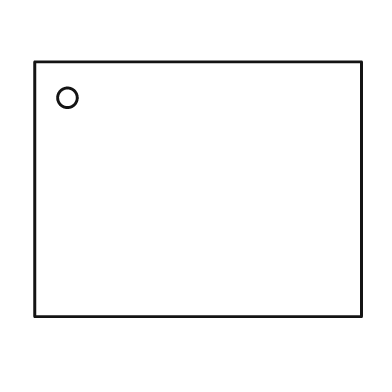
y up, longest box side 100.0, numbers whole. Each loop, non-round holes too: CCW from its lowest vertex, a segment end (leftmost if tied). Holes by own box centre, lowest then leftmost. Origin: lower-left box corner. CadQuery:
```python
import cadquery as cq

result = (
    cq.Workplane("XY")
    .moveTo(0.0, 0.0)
    .lineTo(100.0, 0.0)
    .lineTo(100.0, 78.0)
    .lineTo(0.0, 78.0)
    .close()
    .moveTo(10.0, 67.0)
    .circle(3.0)
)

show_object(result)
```